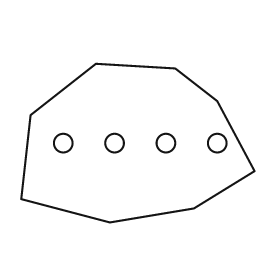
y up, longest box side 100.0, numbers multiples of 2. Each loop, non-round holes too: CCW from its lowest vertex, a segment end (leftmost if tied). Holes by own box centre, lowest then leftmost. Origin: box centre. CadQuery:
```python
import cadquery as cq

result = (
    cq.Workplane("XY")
    .moveTo(-12.0, -34.0)
    .lineTo(24.0, -28.0)
    .lineTo(50.0, -12.0)
    .lineTo(34.0, 18.0)
    .lineTo(16.0, 32.0)
    .lineTo(-18.0, 34.0)
    .lineTo(-46.0, 12.0)
    .lineTo(-50.0, -24.0)
    .close()
    .moveTo(-32.0, 0.0)
    .circle(4.0)
    .moveTo(-10.0, 0.0)
    .circle(4.0)
    .moveTo(12.0, 0.0)
    .circle(4.0)
    .moveTo(34.0, 0.0)
    .circle(4.0)
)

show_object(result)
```